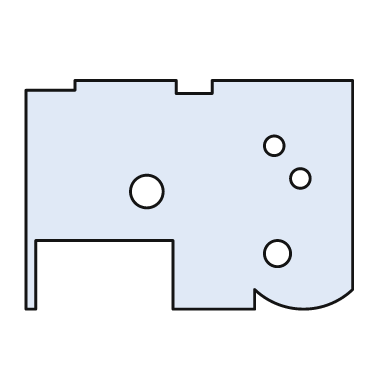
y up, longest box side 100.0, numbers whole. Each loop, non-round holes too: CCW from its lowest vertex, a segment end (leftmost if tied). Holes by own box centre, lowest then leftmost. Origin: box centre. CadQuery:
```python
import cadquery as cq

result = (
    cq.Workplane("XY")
    .moveTo(-50.0, -35.0)
    .lineTo(-47.0, -35.0)
    .lineTo(-47.0, -14.0)
    .lineTo(-5.0, -14.0)
    .lineTo(-5.0, -35.0)
    .lineTo(20.0, -35.0)
    .lineTo(20.0, -29.0)
    .threePointArc((35.0, -35.0), (50.0, -29.0))
    .lineTo(50.0, 35.0)
    .lineTo(7.0, 35.0)
    .lineTo(7.0, 31.0)
    .lineTo(-4.0, 31.0)
    .lineTo(-4.0, 35.0)
    .lineTo(-35.0, 35.0)
    .lineTo(-35.0, 32.0)
    .lineTo(-50.0, 32.0)
    .close()
    .moveTo(27.0, -18.0)
    .circle(4.0)
    .moveTo(-13.0, 1.0)
    .circle(5.0)
    .moveTo(34.0, 5.0)
    .circle(3.0)
    .moveTo(26.0, 15.0)
    .circle(3.0)
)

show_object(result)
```